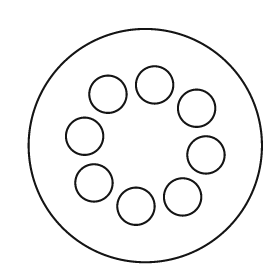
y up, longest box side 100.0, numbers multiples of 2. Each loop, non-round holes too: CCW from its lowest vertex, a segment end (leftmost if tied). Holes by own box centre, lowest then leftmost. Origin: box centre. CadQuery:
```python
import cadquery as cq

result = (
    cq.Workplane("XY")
    .moveTo(0.0, 0.0)
    .circle(50.0)
    .moveTo(-4.0, -26.0)
    .circle(8.0)
    .moveTo(16.0, -22.0)
    .circle(8.0)
    .moveTo(-22.0, -16.0)
    .circle(8.0)
    .moveTo(26.0, -4.0)
    .circle(8.0)
    .moveTo(-26.0, 4.0)
    .circle(8.0)
    .moveTo(22.0, 16.0)
    .circle(8.0)
    .moveTo(-16.0, 22.0)
    .circle(8.0)
    .moveTo(4.0, 26.0)
    .circle(8.0)
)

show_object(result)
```